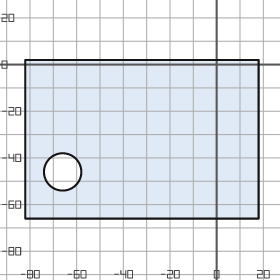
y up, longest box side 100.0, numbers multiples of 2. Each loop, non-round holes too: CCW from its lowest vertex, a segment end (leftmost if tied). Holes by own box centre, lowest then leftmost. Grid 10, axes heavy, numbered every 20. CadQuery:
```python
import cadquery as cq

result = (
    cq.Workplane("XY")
    .moveTo(-82.0, -66.0)
    .lineTo(18.0, -66.0)
    .lineTo(18.0, 2.0)
    .lineTo(-82.0, 2.0)
    .close()
    .moveTo(-66.0, -46.0)
    .circle(8.0)
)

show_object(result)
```